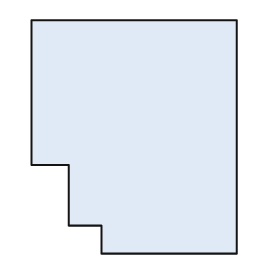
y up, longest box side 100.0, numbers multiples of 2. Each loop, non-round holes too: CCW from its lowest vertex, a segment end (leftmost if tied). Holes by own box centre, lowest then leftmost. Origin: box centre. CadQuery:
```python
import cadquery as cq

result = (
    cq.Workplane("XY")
    .moveTo(-14.0, -50.0)
    .lineTo(44.0, -50.0)
    .lineTo(44.0, 50.0)
    .lineTo(-44.0, 50.0)
    .lineTo(-44.0, -12.0)
    .lineTo(-28.0, -12.0)
    .lineTo(-28.0, -38.0)
    .lineTo(-14.0, -38.0)
    .close()
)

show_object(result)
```